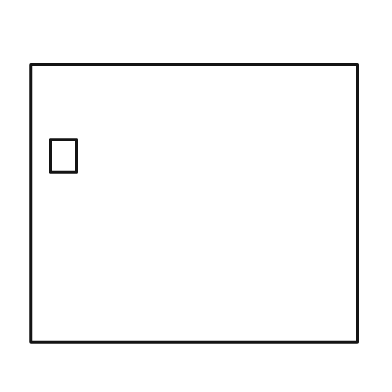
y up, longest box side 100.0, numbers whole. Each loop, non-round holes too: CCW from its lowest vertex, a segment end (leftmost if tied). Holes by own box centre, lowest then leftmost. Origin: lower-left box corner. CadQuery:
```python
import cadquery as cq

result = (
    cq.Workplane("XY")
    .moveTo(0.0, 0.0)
    .lineTo(100.0, 0.0)
    .lineTo(100.0, 85.0)
    .lineTo(0.0, 85.0)
    .close()
    .moveTo(6.0, 52.0)
    .lineTo(14.0, 52.0)
    .lineTo(14.0, 62.0)
    .lineTo(6.0, 62.0)
    .close()
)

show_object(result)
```